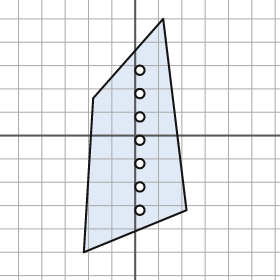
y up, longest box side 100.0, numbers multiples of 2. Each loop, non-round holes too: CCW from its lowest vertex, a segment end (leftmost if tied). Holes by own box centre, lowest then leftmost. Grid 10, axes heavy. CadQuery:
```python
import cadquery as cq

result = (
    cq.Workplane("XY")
    .moveTo(-22.0, -50.0)
    .lineTo(22.0, -32.0)
    .lineTo(12.0, 50.0)
    .lineTo(-18.0, 16.0)
    .close()
    .moveTo(2.0, -32.0)
    .circle(2.0)
    .moveTo(2.0, -22.0)
    .circle(2.0)
    .moveTo(2.0, -12.0)
    .circle(2.0)
    .moveTo(2.0, -2.0)
    .circle(2.0)
    .moveTo(2.0, 8.0)
    .circle(2.0)
    .moveTo(2.0, 18.0)
    .circle(2.0)
    .moveTo(2.0, 28.0)
    .circle(2.0)
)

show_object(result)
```